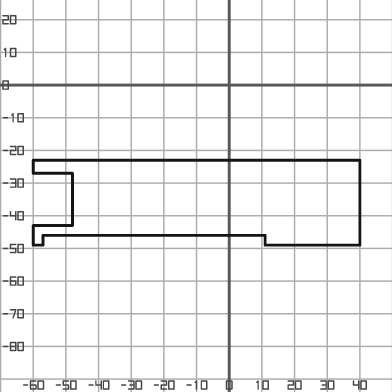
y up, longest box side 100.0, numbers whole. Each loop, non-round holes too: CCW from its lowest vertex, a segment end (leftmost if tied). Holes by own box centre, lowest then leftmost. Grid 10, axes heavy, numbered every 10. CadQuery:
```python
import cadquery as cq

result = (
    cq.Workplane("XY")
    .moveTo(-60.0, -49.0)
    .lineTo(-57.0, -49.0)
    .lineTo(-57.0, -46.0)
    .lineTo(11.0, -46.0)
    .lineTo(11.0, -49.0)
    .lineTo(40.0, -49.0)
    .lineTo(40.0, -23.0)
    .lineTo(-60.0, -23.0)
    .lineTo(-60.0, -27.0)
    .lineTo(-48.0, -27.0)
    .lineTo(-48.0, -43.0)
    .lineTo(-60.0, -43.0)
    .close()
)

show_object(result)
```